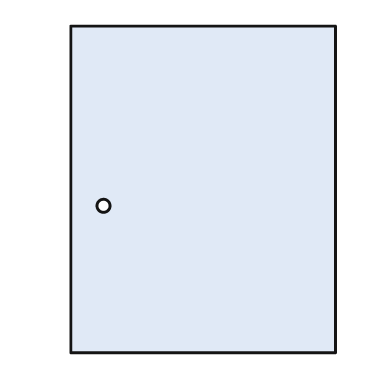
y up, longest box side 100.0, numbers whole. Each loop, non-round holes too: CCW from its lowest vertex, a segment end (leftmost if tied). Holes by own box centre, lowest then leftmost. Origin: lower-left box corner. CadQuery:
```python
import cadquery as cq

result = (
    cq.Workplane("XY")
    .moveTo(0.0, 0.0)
    .lineTo(81.0, 0.0)
    .lineTo(81.0, 100.0)
    .lineTo(0.0, 100.0)
    .close()
    .moveTo(10.0, 45.0)
    .circle(2.0)
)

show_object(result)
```